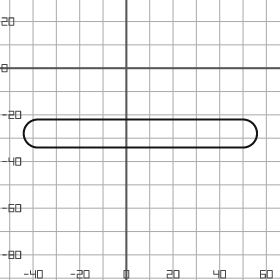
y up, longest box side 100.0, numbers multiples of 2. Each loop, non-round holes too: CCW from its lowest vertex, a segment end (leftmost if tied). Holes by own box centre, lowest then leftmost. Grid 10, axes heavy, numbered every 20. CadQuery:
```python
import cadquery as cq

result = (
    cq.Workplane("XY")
    .moveTo(-38.0, -34.0)
    .lineTo(50.0, -34.0)
    .threePointArc((56.0, -28.0), (50.0, -22.0))
    .lineTo(-38.0, -22.0)
    .threePointArc((-44.0, -28.0), (-38.0, -34.0))
    .close()
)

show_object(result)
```